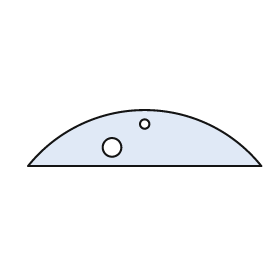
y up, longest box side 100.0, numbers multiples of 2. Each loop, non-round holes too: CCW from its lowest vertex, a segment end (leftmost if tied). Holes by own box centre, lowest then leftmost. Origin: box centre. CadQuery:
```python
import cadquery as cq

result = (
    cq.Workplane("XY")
    .moveTo(-50.0, -12.0)
    .lineTo(50.0, -12.0)
    .threePointArc((0.0, 12.0), (-50.0, -12.0))
    .close()
    .moveTo(-14.0, -4.0)
    .circle(4.0)
    .moveTo(0.0, 6.0)
    .circle(2.0)
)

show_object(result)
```